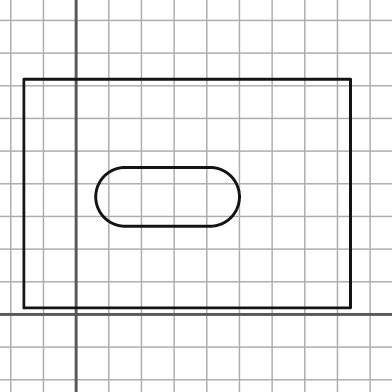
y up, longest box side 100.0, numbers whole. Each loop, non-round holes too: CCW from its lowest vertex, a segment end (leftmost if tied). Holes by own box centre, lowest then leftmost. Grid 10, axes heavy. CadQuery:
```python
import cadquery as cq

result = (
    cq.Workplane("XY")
    .moveTo(-16.0, 2.0)
    .lineTo(84.0, 2.0)
    .lineTo(84.0, 72.0)
    .lineTo(-16.0, 72.0)
    .close()
    .moveTo(15.0, 27.0)
    .lineTo(41.0, 27.0)
    .threePointArc((50.0, 36.0), (41.0, 45.0))
    .lineTo(15.0, 45.0)
    .threePointArc((6.0, 36.0), (15.0, 27.0))
    .close()
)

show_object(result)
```